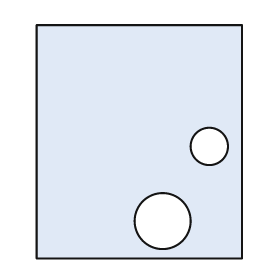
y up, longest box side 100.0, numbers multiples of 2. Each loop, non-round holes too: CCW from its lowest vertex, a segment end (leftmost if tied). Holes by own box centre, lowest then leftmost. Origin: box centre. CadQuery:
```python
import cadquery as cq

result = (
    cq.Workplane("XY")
    .moveTo(-44.0, -50.0)
    .lineTo(44.0, -50.0)
    .lineTo(44.0, 50.0)
    .lineTo(-44.0, 50.0)
    .close()
    .moveTo(10.0, -34.0)
    .circle(12.0)
    .moveTo(30.0, -2.0)
    .circle(8.0)
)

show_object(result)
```